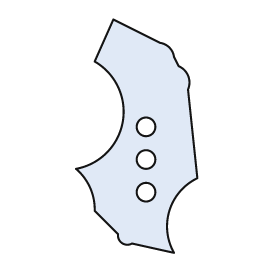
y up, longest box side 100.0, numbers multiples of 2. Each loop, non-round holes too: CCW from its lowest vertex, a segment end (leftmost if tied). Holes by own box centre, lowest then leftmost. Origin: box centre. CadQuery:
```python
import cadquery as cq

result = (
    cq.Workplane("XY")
    .moveTo(16.0, -50.0)
    .threePointArc((14.0, -32.0), (26.0, -18.0))
    .lineTo(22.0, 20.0)
    .threePointArc((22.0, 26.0), (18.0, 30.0))
    .lineTo(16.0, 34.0)
    .threePointArc((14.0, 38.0), (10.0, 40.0))
    .lineTo(-10.0, 50.0)
    .lineTo(-18.0, 32.0)
    .threePointArc((-6.0, 6.0), (-26.0, -14.0))
    .threePointArc((-20.0, -22.0), (-18.0, -32.0))
    .lineTo(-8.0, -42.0)
    .threePointArc((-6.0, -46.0), (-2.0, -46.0))
    .close()
    .moveTo(4.0, -24.0)
    .circle(4.0)
    .moveTo(4.0, -10.0)
    .circle(4.0)
    .moveTo(4.0, 4.0)
    .circle(4.0)
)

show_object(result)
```